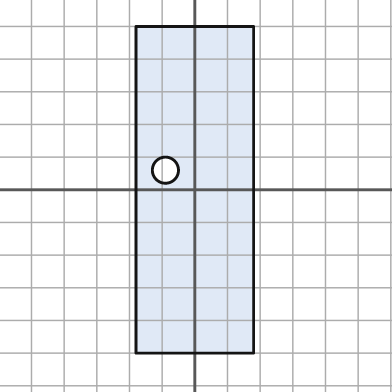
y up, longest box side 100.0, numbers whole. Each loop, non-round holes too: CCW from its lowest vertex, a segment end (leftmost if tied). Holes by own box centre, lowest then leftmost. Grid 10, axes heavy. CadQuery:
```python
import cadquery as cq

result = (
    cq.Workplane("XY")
    .moveTo(-18.0, -50.0)
    .lineTo(18.0, -50.0)
    .lineTo(18.0, 50.0)
    .lineTo(-18.0, 50.0)
    .close()
    .moveTo(-9.0, 6.0)
    .circle(4.0)
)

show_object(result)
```